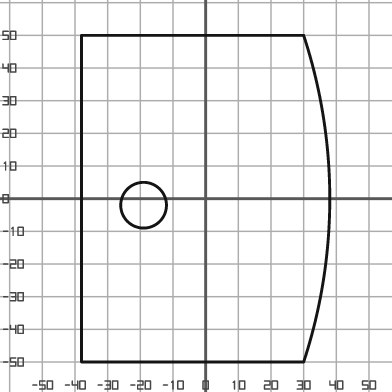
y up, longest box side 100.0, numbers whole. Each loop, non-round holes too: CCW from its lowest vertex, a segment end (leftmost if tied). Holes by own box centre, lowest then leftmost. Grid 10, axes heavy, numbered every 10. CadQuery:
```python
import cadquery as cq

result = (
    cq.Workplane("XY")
    .moveTo(-38.0, -50.0)
    .lineTo(30.0, -50.0)
    .threePointArc((38.0, 0.0), (30.0, 50.0))
    .lineTo(-38.0, 50.0)
    .close()
    .moveTo(-19.0, -2.0)
    .circle(7.0)
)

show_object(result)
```